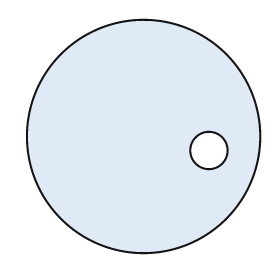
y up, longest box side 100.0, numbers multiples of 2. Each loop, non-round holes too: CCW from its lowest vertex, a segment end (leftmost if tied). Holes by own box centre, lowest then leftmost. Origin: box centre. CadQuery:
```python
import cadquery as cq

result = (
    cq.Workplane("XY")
    .moveTo(0.0, 0.0)
    .circle(50.0)
    .moveTo(28.0, -6.0)
    .circle(8.0)
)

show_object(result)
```